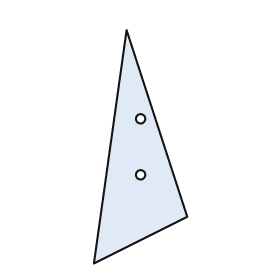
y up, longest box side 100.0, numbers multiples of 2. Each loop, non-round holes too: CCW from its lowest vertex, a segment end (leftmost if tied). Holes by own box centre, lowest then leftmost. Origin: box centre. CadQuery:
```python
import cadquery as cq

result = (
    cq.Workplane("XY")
    .moveTo(-20.0, -50.0)
    .lineTo(20.0, -30.0)
    .lineTo(-6.0, 50.0)
    .close()
    .moveTo(0.0, -12.0)
    .circle(2.0)
    .moveTo(0.0, 12.0)
    .circle(2.0)
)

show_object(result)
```